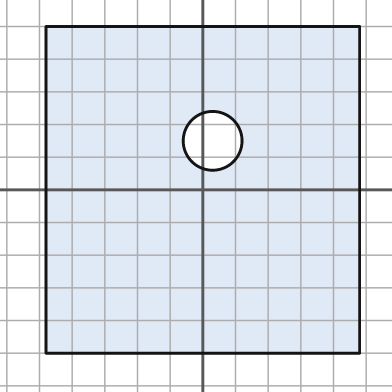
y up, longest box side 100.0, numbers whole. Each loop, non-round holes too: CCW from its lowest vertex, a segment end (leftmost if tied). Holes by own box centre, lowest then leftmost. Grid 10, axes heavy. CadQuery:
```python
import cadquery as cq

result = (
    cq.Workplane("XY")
    .moveTo(-48.0, -50.0)
    .lineTo(48.0, -50.0)
    .lineTo(48.0, 50.0)
    .lineTo(-48.0, 50.0)
    .close()
    .moveTo(3.0, 15.0)
    .circle(9.0)
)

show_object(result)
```